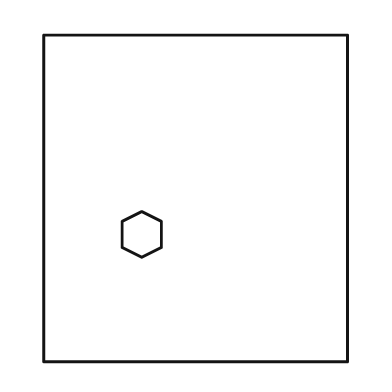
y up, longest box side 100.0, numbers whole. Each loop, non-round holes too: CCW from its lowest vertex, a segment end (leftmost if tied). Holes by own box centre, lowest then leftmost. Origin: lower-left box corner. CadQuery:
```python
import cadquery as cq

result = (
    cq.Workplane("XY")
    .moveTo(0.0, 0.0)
    .lineTo(93.0, 0.0)
    .lineTo(93.0, 100.0)
    .lineTo(0.0, 100.0)
    .close()
    .moveTo(30.0, 32.0)
    .lineTo(36.0, 35.0)
    .lineTo(36.0, 43.0)
    .lineTo(30.0, 46.0)
    .lineTo(24.0, 43.0)
    .lineTo(24.0, 35.0)
    .close()
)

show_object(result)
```